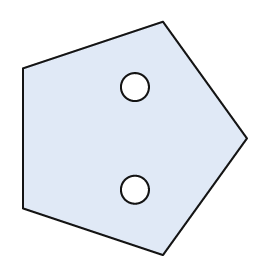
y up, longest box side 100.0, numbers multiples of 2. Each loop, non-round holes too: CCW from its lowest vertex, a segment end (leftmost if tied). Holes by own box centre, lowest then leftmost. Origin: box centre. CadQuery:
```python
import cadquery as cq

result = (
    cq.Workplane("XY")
    .moveTo(12.0, -50.0)
    .lineTo(48.0, 0.0)
    .lineTo(12.0, 50.0)
    .lineTo(-48.0, 30.0)
    .lineTo(-48.0, -30.0)
    .close()
    .moveTo(0.0, -22.0)
    .circle(6.0)
    .moveTo(0.0, 22.0)
    .circle(6.0)
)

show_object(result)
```